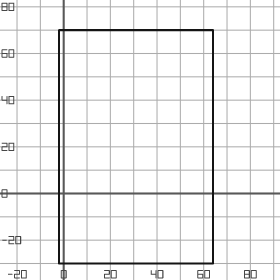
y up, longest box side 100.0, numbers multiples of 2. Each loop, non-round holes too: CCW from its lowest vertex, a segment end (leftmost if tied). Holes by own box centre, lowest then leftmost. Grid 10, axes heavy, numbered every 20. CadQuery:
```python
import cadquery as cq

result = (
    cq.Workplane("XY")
    .moveTo(-2.0, -30.0)
    .lineTo(64.0, -30.0)
    .lineTo(64.0, 70.0)
    .lineTo(-2.0, 70.0)
    .close()
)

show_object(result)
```